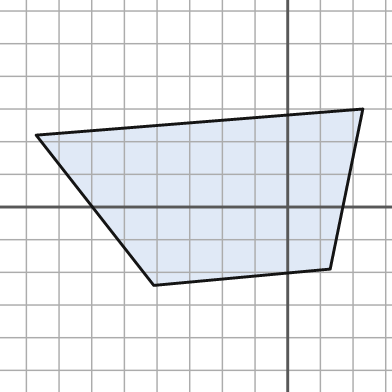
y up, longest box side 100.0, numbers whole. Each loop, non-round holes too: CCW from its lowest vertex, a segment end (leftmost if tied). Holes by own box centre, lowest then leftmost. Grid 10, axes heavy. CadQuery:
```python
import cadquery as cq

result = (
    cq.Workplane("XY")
    .moveTo(-41.0, -24.0)
    .lineTo(13.0, -19.0)
    .lineTo(23.0, 30.0)
    .lineTo(-77.0, 22.0)
    .close()
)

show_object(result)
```